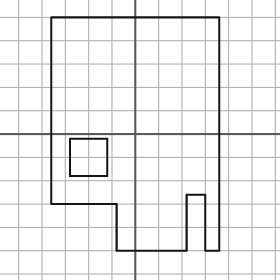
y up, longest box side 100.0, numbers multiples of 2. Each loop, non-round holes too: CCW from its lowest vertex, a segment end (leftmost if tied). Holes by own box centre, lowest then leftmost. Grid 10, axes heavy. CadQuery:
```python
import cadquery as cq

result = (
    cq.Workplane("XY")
    .moveTo(-8.0, -50.0)
    .lineTo(22.0, -50.0)
    .lineTo(22.0, -26.0)
    .lineTo(30.0, -26.0)
    .lineTo(30.0, -50.0)
    .lineTo(36.0, -50.0)
    .lineTo(36.0, 50.0)
    .lineTo(-36.0, 50.0)
    .lineTo(-36.0, -30.0)
    .lineTo(-8.0, -30.0)
    .close()
    .moveTo(-28.0, -18.0)
    .lineTo(-12.0, -18.0)
    .lineTo(-12.0, -2.0)
    .lineTo(-28.0, -2.0)
    .close()
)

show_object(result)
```